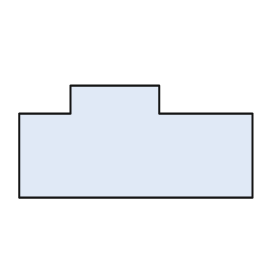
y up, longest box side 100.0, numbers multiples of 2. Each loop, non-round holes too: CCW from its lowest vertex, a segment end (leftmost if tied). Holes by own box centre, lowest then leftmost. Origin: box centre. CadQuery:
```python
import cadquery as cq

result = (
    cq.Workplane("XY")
    .moveTo(-50.0, -24.0)
    .lineTo(50.0, -24.0)
    .lineTo(50.0, 12.0)
    .lineTo(10.0, 12.0)
    .lineTo(10.0, 24.0)
    .lineTo(-28.0, 24.0)
    .lineTo(-28.0, 12.0)
    .lineTo(-50.0, 12.0)
    .close()
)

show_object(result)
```